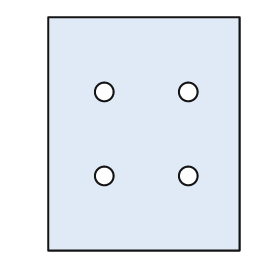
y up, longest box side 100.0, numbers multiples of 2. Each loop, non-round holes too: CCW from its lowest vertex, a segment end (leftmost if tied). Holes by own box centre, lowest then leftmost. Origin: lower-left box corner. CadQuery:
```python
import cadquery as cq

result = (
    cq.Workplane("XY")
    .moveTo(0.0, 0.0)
    .lineTo(82.0, 0.0)
    .lineTo(82.0, 100.0)
    .lineTo(0.0, 100.0)
    .close()
    .moveTo(24.0, 32.0)
    .circle(4.0)
    .moveTo(60.0, 32.0)
    .circle(4.0)
    .moveTo(24.0, 68.0)
    .circle(4.0)
    .moveTo(60.0, 68.0)
    .circle(4.0)
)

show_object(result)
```